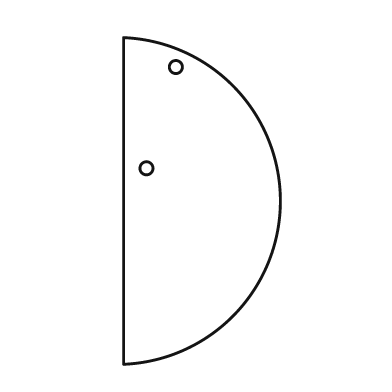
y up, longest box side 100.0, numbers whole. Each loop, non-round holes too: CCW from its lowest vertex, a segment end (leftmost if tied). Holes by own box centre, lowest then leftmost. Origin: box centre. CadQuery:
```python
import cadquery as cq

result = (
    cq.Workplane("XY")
    .moveTo(-24.0, -50.0)
    .threePointArc((24.0, 0.0), (-24.0, 50.0))
    .close()
    .moveTo(-17.0, 10.0)
    .circle(2.0)
    .moveTo(-8.0, 41.0)
    .circle(2.0)
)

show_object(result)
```